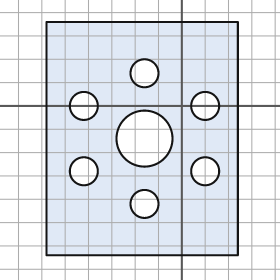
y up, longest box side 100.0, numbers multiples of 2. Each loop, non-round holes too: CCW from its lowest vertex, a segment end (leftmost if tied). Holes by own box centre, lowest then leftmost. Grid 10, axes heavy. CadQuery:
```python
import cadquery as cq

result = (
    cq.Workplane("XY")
    .moveTo(-58.0, -64.0)
    .lineTo(24.0, -64.0)
    .lineTo(24.0, 36.0)
    .lineTo(-58.0, 36.0)
    .close()
    .moveTo(-16.0, -42.0)
    .circle(6.0)
    .moveTo(-42.0, -28.0)
    .circle(6.0)
    .moveTo(10.0, -28.0)
    .circle(6.0)
    .moveTo(-16.0, -14.0)
    .circle(12.0)
    .moveTo(-42.0, 0.0)
    .circle(6.0)
    .moveTo(10.0, 0.0)
    .circle(6.0)
    .moveTo(-16.0, 14.0)
    .circle(6.0)
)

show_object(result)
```